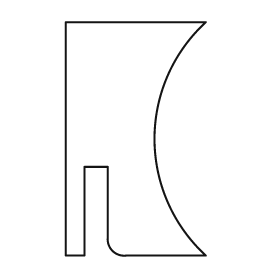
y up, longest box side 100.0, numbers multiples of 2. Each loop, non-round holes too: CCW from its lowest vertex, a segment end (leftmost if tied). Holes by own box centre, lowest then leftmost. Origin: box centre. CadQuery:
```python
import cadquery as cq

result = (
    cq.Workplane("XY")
    .moveTo(-30.0, -50.0)
    .lineTo(-22.0, -50.0)
    .lineTo(-22.0, -12.0)
    .lineTo(-12.0, -12.0)
    .lineTo(-12.0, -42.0)
    .threePointArc((-10.0, -48.0), (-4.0, -50.0))
    .lineTo(30.0, -50.0)
    .threePointArc((8.0, 0.0), (30.0, 50.0))
    .lineTo(-30.0, 50.0)
    .close()
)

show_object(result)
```